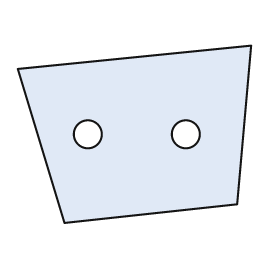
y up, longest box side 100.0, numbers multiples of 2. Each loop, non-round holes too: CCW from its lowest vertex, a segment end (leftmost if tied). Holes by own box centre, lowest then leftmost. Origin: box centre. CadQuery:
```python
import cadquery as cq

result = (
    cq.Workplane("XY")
    .moveTo(-30.0, -38.0)
    .lineTo(44.0, -30.0)
    .lineTo(50.0, 38.0)
    .lineTo(-50.0, 28.0)
    .close()
    .moveTo(-20.0, 0.0)
    .circle(6.0)
    .moveTo(22.0, 0.0)
    .circle(6.0)
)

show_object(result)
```